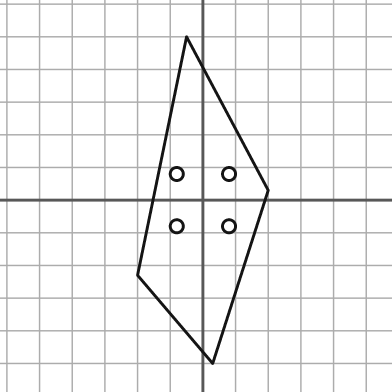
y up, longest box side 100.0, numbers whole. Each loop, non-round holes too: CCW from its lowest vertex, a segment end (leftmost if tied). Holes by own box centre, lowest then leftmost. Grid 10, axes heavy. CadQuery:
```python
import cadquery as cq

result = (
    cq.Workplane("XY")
    .moveTo(3.0, -50.0)
    .lineTo(20.0, 3.0)
    .lineTo(-5.0, 50.0)
    .lineTo(-20.0, -23.0)
    .close()
    .moveTo(-8.0, -8.0)
    .circle(2.0)
    .moveTo(8.0, -8.0)
    .circle(2.0)
    .moveTo(-8.0, 8.0)
    .circle(2.0)
    .moveTo(8.0, 8.0)
    .circle(2.0)
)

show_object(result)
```